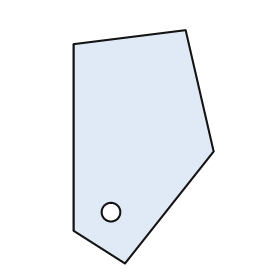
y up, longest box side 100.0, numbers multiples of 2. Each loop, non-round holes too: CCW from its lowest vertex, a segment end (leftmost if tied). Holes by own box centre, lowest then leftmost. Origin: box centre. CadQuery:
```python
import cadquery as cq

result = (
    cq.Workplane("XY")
    .moveTo(-8.0, -50.0)
    .lineTo(30.0, -2.0)
    .lineTo(18.0, 50.0)
    .lineTo(-30.0, 44.0)
    .lineTo(-30.0, -36.0)
    .close()
    .moveTo(-14.0, -28.0)
    .circle(4.0)
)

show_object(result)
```